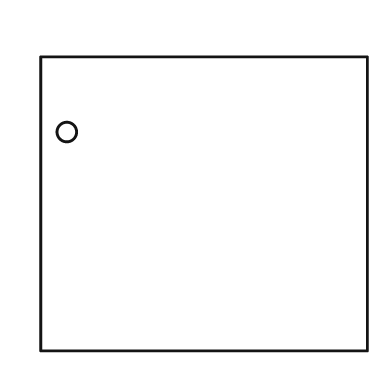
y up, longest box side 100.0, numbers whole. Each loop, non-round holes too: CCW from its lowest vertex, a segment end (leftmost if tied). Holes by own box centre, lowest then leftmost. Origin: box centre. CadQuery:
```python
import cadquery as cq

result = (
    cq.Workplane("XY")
    .moveTo(-50.0, -45.0)
    .lineTo(50.0, -45.0)
    .lineTo(50.0, 45.0)
    .lineTo(-50.0, 45.0)
    .close()
    .moveTo(-42.0, 22.0)
    .circle(3.0)
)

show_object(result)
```